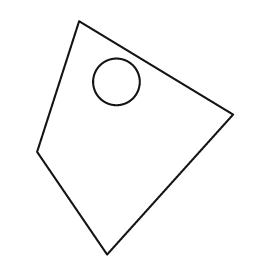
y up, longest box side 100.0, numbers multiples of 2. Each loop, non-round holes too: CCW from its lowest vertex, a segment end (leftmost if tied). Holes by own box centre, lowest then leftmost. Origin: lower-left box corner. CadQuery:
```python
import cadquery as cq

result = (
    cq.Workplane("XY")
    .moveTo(30.0, 0.0)
    .lineTo(84.0, 60.0)
    .lineTo(18.0, 100.0)
    .lineTo(0.0, 44.0)
    .close()
    .moveTo(34.0, 74.0)
    .circle(10.0)
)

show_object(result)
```